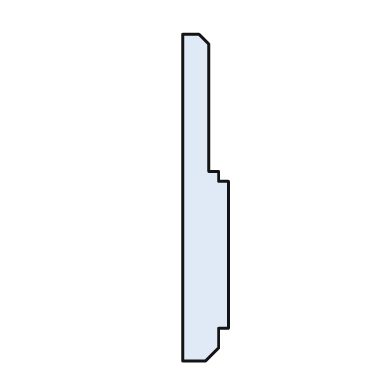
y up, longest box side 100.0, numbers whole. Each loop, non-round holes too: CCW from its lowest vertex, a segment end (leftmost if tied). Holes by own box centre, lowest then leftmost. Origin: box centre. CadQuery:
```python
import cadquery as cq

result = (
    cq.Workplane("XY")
    .moveTo(-7.0, -50.0)
    .lineTo(0.0, -50.0)
    .lineTo(4.0, -46.0)
    .lineTo(4.0, -40.0)
    .lineTo(7.0, -40.0)
    .lineTo(7.0, 5.0)
    .lineTo(4.0, 5.0)
    .lineTo(4.0, 8.0)
    .lineTo(1.0, 8.0)
    .lineTo(1.0, 47.0)
    .lineTo(-2.0, 50.0)
    .lineTo(-7.0, 50.0)
    .close()
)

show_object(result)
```